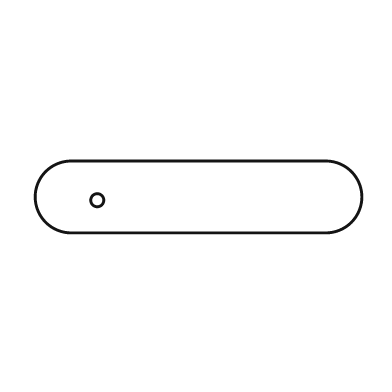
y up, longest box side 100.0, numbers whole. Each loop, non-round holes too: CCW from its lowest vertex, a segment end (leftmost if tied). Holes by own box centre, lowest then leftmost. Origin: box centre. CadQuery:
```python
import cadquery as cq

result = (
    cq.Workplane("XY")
    .moveTo(-39.0, -11.0)
    .lineTo(39.0, -11.0)
    .threePointArc((50.0, 0.0), (39.0, 11.0))
    .lineTo(-39.0, 11.0)
    .threePointArc((-50.0, 0.0), (-39.0, -11.0))
    .close()
    .moveTo(-31.0, -1.0)
    .circle(2.0)
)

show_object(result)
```